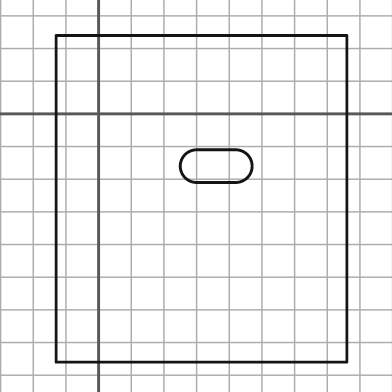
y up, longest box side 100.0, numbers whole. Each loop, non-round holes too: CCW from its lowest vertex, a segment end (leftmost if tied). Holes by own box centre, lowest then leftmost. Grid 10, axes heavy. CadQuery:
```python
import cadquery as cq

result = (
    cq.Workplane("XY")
    .moveTo(-13.0, -76.0)
    .lineTo(76.0, -76.0)
    .lineTo(76.0, 24.0)
    .lineTo(-13.0, 24.0)
    .close()
    .moveTo(30.0, -21.0)
    .lineTo(42.0, -21.0)
    .threePointArc((47.0, -16.0), (42.0, -11.0))
    .lineTo(30.0, -11.0)
    .threePointArc((25.0, -16.0), (30.0, -21.0))
    .close()
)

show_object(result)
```